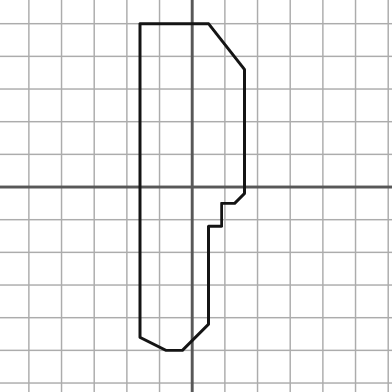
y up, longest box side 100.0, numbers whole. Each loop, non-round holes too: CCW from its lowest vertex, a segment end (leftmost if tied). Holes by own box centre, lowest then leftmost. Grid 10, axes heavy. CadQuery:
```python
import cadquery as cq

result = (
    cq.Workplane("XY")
    .moveTo(-8.0, -50.0)
    .lineTo(-3.0, -50.0)
    .lineTo(5.0, -42.0)
    .lineTo(5.0, -12.0)
    .lineTo(9.0, -12.0)
    .lineTo(9.0, -5.0)
    .lineTo(13.0, -5.0)
    .lineTo(16.0, -2.0)
    .lineTo(16.0, 36.0)
    .lineTo(5.0, 50.0)
    .lineTo(-16.0, 50.0)
    .lineTo(-16.0, -46.0)
    .close()
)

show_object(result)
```